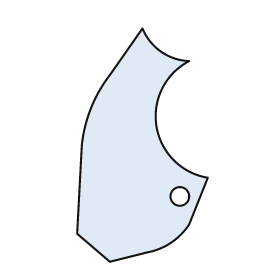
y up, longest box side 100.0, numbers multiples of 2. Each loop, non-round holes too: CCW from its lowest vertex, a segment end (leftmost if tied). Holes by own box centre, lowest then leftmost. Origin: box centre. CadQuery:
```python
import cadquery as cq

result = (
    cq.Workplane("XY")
    .moveTo(-14.0, -50.0)
    .lineTo(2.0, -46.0)
    .threePointArc((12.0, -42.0), (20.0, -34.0))
    .lineTo(28.0, -14.0)
    .threePointArc((6.0, 8.0), (20.0, 36.0))
    .threePointArc((8.0, 40.0), (0.0, 50.0))
    .lineTo(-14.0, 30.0)
    .threePointArc((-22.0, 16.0), (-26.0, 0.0))
    .lineTo(-28.0, -38.0)
    .close()
    .moveTo(16.0, -22.0)
    .circle(4.0)
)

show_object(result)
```